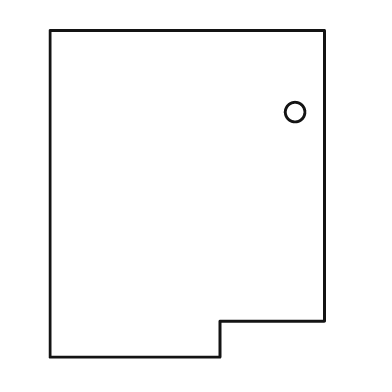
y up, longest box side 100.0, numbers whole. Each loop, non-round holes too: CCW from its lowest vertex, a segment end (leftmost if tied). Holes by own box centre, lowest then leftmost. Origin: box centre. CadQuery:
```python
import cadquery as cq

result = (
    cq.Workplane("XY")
    .moveTo(-42.0, -50.0)
    .lineTo(10.0, -50.0)
    .lineTo(10.0, -39.0)
    .lineTo(42.0, -39.0)
    .lineTo(42.0, 50.0)
    .lineTo(-42.0, 50.0)
    .close()
    .moveTo(33.0, 25.0)
    .circle(3.0)
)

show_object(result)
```